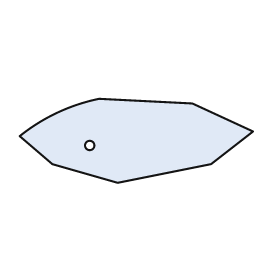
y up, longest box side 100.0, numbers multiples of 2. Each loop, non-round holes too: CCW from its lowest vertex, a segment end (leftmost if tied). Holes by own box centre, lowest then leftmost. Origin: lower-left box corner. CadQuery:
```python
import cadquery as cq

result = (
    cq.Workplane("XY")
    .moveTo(42.0, 0.0)
    .lineTo(82.0, 8.0)
    .lineTo(100.0, 22.0)
    .lineTo(74.0, 34.0)
    .lineTo(34.0, 36.0)
    .threePointArc((16.0, 30.0), (0.0, 20.0))
    .lineTo(14.0, 8.0)
    .close()
    .moveTo(30.0, 16.0)
    .circle(2.0)
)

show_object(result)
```